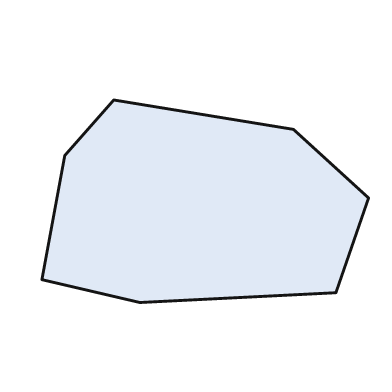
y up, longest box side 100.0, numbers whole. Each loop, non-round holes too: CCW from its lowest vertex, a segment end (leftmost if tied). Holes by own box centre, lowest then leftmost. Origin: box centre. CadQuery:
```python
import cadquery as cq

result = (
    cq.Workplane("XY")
    .moveTo(-20.0, -31.0)
    .lineTo(40.0, -28.0)
    .lineTo(50.0, 1.0)
    .lineTo(27.0, 22.0)
    .lineTo(-28.0, 31.0)
    .lineTo(-43.0, 14.0)
    .lineTo(-50.0, -24.0)
    .close()
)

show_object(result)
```